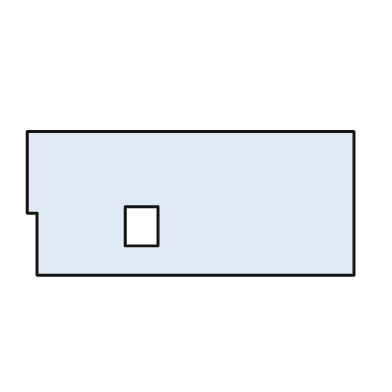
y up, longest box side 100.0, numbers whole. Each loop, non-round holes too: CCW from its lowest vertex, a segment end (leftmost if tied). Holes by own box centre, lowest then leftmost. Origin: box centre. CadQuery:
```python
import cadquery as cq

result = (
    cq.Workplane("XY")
    .moveTo(-47.0, -22.0)
    .lineTo(50.0, -22.0)
    .lineTo(50.0, 22.0)
    .lineTo(-50.0, 22.0)
    .lineTo(-50.0, -3.0)
    .lineTo(-47.0, -3.0)
    .close()
    .moveTo(-20.0, -13.0)
    .lineTo(-10.0, -13.0)
    .lineTo(-10.0, -1.0)
    .lineTo(-20.0, -1.0)
    .close()
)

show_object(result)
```